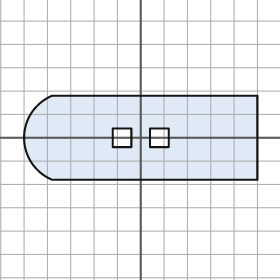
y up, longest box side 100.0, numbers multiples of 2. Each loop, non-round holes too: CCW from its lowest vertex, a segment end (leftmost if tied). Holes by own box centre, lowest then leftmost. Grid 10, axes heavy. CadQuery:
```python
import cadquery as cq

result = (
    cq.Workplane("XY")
    .moveTo(-38.0, -18.0)
    .lineTo(50.0, -18.0)
    .lineTo(50.0, 18.0)
    .lineTo(-38.0, 18.0)
    .threePointArc((-50.0, 0.0), (-38.0, -18.0))
    .close()
    .moveTo(-12.0, -4.0)
    .lineTo(-4.0, -4.0)
    .lineTo(-4.0, 4.0)
    .lineTo(-12.0, 4.0)
    .close()
    .moveTo(4.0, -4.0)
    .lineTo(12.0, -4.0)
    .lineTo(12.0, 4.0)
    .lineTo(4.0, 4.0)
    .close()
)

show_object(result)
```